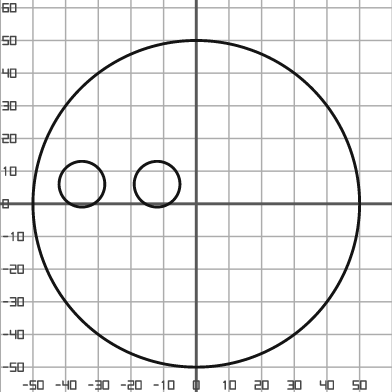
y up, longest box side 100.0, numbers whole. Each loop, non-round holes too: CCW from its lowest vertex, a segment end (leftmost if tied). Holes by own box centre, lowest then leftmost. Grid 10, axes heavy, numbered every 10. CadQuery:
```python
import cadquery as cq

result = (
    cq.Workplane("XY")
    .moveTo(0.0, 0.0)
    .circle(50.0)
    .moveTo(-35.0, 6.0)
    .circle(7.0)
    .moveTo(-12.0, 6.0)
    .circle(7.0)
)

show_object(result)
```